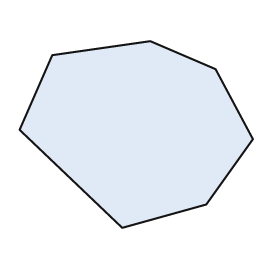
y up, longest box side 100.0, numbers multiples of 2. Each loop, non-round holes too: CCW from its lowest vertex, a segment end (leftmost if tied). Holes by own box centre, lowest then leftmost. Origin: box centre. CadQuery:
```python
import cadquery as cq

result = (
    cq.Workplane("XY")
    .moveTo(-6.0, -40.0)
    .lineTo(30.0, -30.0)
    .lineTo(50.0, -2.0)
    .lineTo(34.0, 28.0)
    .lineTo(6.0, 40.0)
    .lineTo(-36.0, 34.0)
    .lineTo(-50.0, 2.0)
    .close()
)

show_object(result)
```